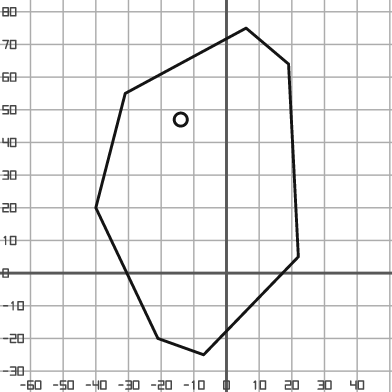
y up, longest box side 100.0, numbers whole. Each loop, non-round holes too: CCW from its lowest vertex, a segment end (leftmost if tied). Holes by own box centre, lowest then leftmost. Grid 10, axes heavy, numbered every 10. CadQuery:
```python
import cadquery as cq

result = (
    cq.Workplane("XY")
    .moveTo(-7.0, -25.0)
    .lineTo(22.0, 5.0)
    .lineTo(19.0, 64.0)
    .lineTo(6.0, 75.0)
    .lineTo(-31.0, 55.0)
    .lineTo(-40.0, 20.0)
    .lineTo(-21.0, -20.0)
    .close()
    .moveTo(-14.0, 47.0)
    .circle(2.0)
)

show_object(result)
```